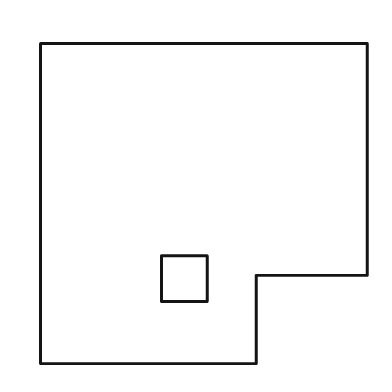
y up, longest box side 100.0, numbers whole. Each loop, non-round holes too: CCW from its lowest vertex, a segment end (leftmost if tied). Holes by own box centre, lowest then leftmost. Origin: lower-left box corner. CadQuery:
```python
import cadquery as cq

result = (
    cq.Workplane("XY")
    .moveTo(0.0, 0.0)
    .lineTo(66.0, 0.0)
    .lineTo(66.0, 27.0)
    .lineTo(100.0, 27.0)
    .lineTo(100.0, 98.0)
    .lineTo(0.0, 98.0)
    .close()
    .moveTo(37.0, 19.0)
    .lineTo(51.0, 19.0)
    .lineTo(51.0, 33.0)
    .lineTo(37.0, 33.0)
    .close()
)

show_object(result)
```